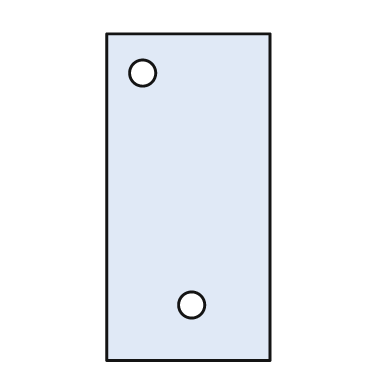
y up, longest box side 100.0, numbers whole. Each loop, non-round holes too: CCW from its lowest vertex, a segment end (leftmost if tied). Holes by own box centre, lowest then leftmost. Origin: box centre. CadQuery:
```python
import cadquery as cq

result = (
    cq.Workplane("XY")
    .moveTo(-25.0, -50.0)
    .lineTo(25.0, -50.0)
    .lineTo(25.0, 50.0)
    .lineTo(-25.0, 50.0)
    .close()
    .moveTo(1.0, -33.0)
    .circle(4.0)
    .moveTo(-14.0, 38.0)
    .circle(4.0)
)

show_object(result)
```